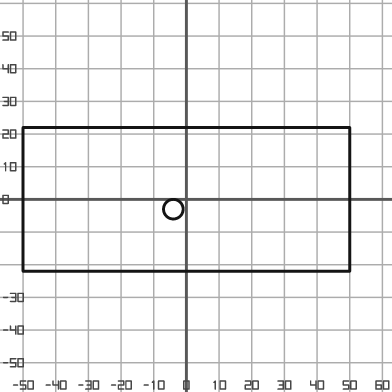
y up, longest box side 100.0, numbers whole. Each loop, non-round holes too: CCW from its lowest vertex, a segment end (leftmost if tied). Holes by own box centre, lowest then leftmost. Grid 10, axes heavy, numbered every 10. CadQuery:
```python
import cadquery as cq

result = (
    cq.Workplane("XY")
    .moveTo(-50.0, -22.0)
    .lineTo(50.0, -22.0)
    .lineTo(50.0, 22.0)
    .lineTo(-50.0, 22.0)
    .close()
    .moveTo(-4.0, -3.0)
    .circle(3.0)
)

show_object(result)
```